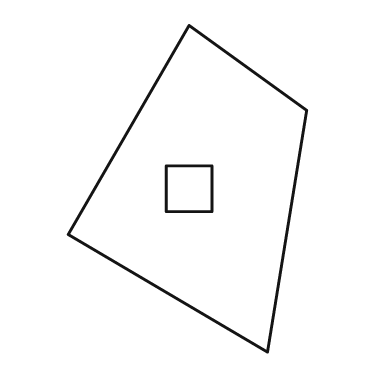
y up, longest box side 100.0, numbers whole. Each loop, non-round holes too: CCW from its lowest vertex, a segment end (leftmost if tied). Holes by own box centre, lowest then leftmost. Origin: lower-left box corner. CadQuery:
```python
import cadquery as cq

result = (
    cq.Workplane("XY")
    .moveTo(61.0, 0.0)
    .lineTo(73.0, 74.0)
    .lineTo(37.0, 100.0)
    .lineTo(0.0, 36.0)
    .close()
    .moveTo(30.0, 43.0)
    .lineTo(44.0, 43.0)
    .lineTo(44.0, 57.0)
    .lineTo(30.0, 57.0)
    .close()
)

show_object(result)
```